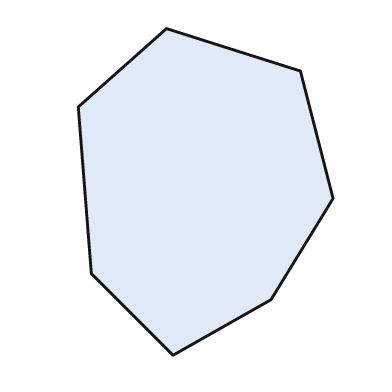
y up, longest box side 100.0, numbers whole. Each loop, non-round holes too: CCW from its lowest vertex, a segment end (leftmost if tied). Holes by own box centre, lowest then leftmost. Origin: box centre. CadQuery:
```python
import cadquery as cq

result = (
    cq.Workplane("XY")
    .moveTo(-10.0, -50.0)
    .lineTo(20.0, -33.0)
    .lineTo(39.0, -2.0)
    .lineTo(29.0, 37.0)
    .lineTo(-12.0, 50.0)
    .lineTo(-39.0, 26.0)
    .lineTo(-35.0, -25.0)
    .close()
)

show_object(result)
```